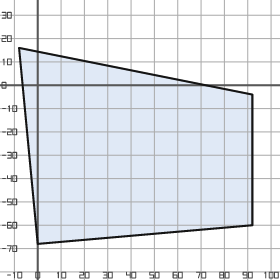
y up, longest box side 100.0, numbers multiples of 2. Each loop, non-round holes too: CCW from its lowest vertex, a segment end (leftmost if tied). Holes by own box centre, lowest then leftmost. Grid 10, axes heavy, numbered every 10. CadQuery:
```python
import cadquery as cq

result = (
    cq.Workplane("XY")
    .moveTo(0.0, -68.0)
    .lineTo(92.0, -60.0)
    .lineTo(92.0, -4.0)
    .lineTo(-8.0, 16.0)
    .close()
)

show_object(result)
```